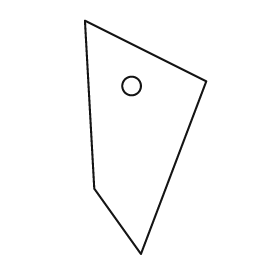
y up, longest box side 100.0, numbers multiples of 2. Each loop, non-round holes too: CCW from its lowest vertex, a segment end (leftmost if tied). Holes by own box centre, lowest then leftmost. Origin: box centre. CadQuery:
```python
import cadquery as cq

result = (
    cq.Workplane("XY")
    .moveTo(-2.0, -50.0)
    .lineTo(26.0, 24.0)
    .lineTo(-26.0, 50.0)
    .lineTo(-22.0, -22.0)
    .close()
    .moveTo(-6.0, 22.0)
    .circle(4.0)
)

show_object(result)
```